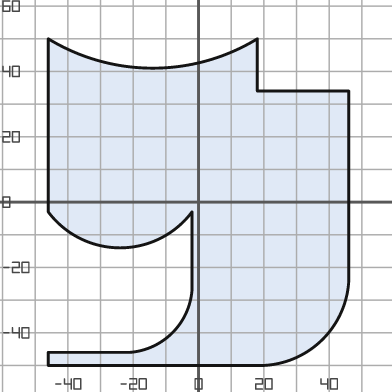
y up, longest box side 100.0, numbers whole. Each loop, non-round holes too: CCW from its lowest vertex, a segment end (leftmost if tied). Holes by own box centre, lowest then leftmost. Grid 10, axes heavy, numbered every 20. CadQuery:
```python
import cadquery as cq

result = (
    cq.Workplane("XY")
    .moveTo(-46.0, -50.0)
    .lineTo(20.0, -50.0)
    .threePointArc((38.0, -42.0), (46.0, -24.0))
    .lineTo(46.0, 34.0)
    .lineTo(18.0, 34.0)
    .lineTo(18.0, 50.0)
    .threePointArc((-14.0, 41.0), (-46.0, 50.0))
    .lineTo(-46.0, -3.0)
    .threePointArc((-24.0, -14.0), (-2.0, -3.0))
    .lineTo(-2.0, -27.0)
    .threePointArc((-8.0, -40.0), (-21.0, -46.0))
    .lineTo(-46.0, -46.0)
    .close()
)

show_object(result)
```